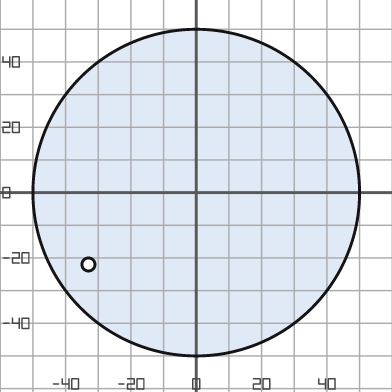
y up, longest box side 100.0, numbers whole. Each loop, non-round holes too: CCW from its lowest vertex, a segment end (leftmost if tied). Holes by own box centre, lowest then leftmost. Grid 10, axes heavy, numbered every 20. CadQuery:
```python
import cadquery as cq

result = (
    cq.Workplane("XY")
    .moveTo(0.0, 0.0)
    .circle(50.0)
    .moveTo(-33.0, -22.0)
    .circle(2.0)
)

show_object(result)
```